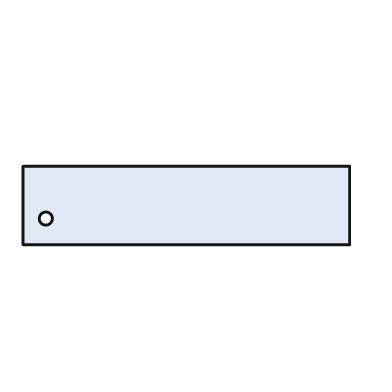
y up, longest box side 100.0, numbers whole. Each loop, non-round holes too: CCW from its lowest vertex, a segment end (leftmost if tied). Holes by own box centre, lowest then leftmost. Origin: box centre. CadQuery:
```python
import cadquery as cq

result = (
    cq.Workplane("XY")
    .moveTo(-50.0, -12.0)
    .lineTo(50.0, -12.0)
    .lineTo(50.0, 12.0)
    .lineTo(-50.0, 12.0)
    .close()
    .moveTo(-43.0, -4.0)
    .circle(2.0)
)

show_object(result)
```